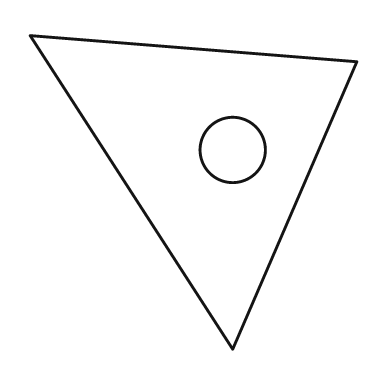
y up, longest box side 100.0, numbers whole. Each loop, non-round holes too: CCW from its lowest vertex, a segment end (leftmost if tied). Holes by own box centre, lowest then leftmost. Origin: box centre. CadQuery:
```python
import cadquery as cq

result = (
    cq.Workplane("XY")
    .moveTo(12.0, -48.0)
    .lineTo(50.0, 40.0)
    .lineTo(-50.0, 48.0)
    .close()
    .moveTo(12.0, 13.0)
    .circle(10.0)
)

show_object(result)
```